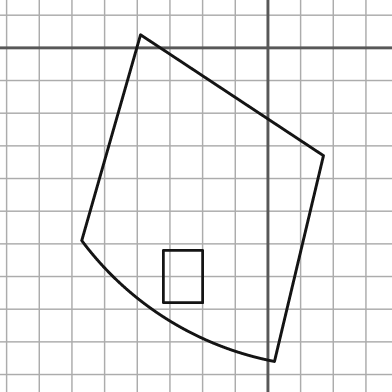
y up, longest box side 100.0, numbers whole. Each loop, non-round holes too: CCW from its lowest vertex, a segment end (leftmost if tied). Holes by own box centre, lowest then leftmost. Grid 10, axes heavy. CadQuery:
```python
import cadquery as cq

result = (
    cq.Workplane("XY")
    .moveTo(2.0, -96.0)
    .lineTo(17.0, -33.0)
    .lineTo(-39.0, 4.0)
    .lineTo(-57.0, -59.0)
    .threePointArc((-31.0, -83.0), (2.0, -96.0))
    .close()
    .moveTo(-32.0, -78.0)
    .lineTo(-20.0, -78.0)
    .lineTo(-20.0, -62.0)
    .lineTo(-32.0, -62.0)
    .close()
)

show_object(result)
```